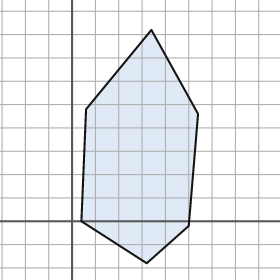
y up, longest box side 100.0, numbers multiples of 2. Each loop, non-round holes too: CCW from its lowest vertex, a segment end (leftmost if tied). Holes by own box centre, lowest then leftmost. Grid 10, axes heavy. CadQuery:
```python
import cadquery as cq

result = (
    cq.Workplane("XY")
    .moveTo(32.0, -18.0)
    .lineTo(50.0, -2.0)
    .lineTo(54.0, 46.0)
    .lineTo(34.0, 82.0)
    .lineTo(6.0, 48.0)
    .lineTo(4.0, 0.0)
    .close()
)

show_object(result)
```